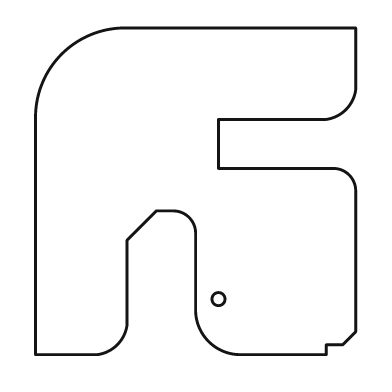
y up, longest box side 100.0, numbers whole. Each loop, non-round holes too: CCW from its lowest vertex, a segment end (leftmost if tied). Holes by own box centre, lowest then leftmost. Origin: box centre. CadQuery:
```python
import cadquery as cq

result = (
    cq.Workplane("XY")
    .moveTo(-49.0, -50.0)
    .lineTo(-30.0, -50.0)
    .threePointArc((-24.0, -47.0), (-21.0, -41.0))
    .lineTo(-21.0, -15.0)
    .lineTo(-12.0, -6.0)
    .lineTo(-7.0, -6.0)
    .threePointArc((-2.0, -8.0), (0.0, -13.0))
    .lineTo(0.0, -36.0)
    .threePointArc((4.0, -46.0), (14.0, -50.0))
    .lineTo(40.0, -50.0)
    .lineTo(40.0, -47.0)
    .lineTo(45.0, -47.0)
    .lineTo(49.0, -43.0)
    .lineTo(49.0, 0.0)
    .threePointArc((47.0, 5.0), (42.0, 7.0))
    .lineTo(7.0, 7.0)
    .lineTo(7.0, 22.0)
    .lineTo(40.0, 22.0)
    .threePointArc((46.0, 25.0), (49.0, 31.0))
    .lineTo(49.0, 50.0)
    .lineTo(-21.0, 50.0)
    .threePointArc((-41.0, 42.0), (-49.0, 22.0))
    .close()
    .moveTo(7.0, -33.0)
    .circle(2.0)
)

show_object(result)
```